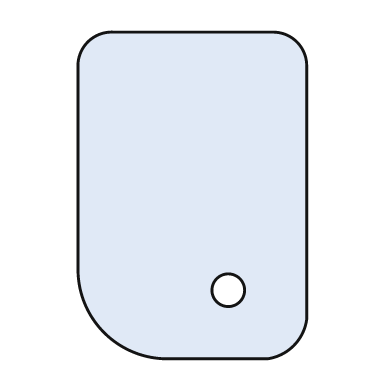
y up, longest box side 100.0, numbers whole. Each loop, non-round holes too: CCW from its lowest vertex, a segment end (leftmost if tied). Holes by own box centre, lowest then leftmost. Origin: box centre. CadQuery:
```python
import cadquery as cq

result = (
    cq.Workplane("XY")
    .moveTo(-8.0, -50.0)
    .lineTo(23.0, -50.0)
    .threePointArc((31.0, -46.0), (35.0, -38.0))
    .lineTo(35.0, 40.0)
    .threePointArc((32.0, 47.0), (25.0, 50.0))
    .lineTo(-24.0, 50.0)
    .threePointArc((-32.0, 47.0), (-35.0, 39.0))
    .lineTo(-35.0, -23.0)
    .threePointArc((-27.0, -42.0), (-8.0, -50.0))
    .close()
    .moveTo(11.0, -29.0)
    .circle(5.0)
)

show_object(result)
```